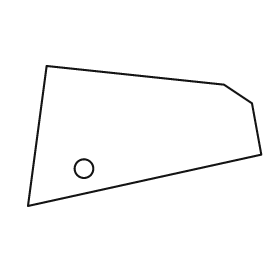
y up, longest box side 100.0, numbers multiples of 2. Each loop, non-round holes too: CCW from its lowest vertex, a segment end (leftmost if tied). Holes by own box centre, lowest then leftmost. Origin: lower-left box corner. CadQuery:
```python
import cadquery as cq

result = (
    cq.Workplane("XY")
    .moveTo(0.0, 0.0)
    .lineTo(100.0, 22.0)
    .lineTo(96.0, 44.0)
    .lineTo(84.0, 52.0)
    .lineTo(8.0, 60.0)
    .close()
    .moveTo(24.0, 16.0)
    .circle(4.0)
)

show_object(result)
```